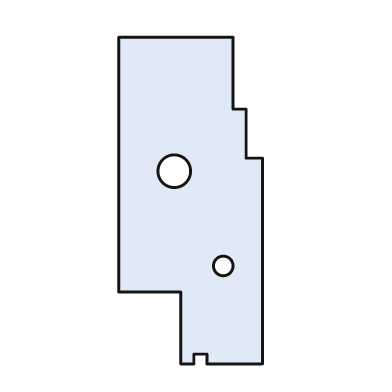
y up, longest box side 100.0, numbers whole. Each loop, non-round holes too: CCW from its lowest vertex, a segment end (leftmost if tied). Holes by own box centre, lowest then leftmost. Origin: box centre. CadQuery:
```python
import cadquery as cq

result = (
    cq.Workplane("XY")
    .moveTo(-3.0, -50.0)
    .lineTo(1.0, -50.0)
    .lineTo(1.0, -47.0)
    .lineTo(5.0, -47.0)
    .lineTo(5.0, -50.0)
    .lineTo(22.0, -50.0)
    .lineTo(22.0, 13.0)
    .lineTo(17.0, 13.0)
    .lineTo(17.0, 28.0)
    .lineTo(13.0, 28.0)
    .lineTo(13.0, 50.0)
    .lineTo(-22.0, 50.0)
    .lineTo(-22.0, -28.0)
    .lineTo(-3.0, -28.0)
    .close()
    .moveTo(10.0, -20.0)
    .circle(3.0)
    .moveTo(-5.0, 9.0)
    .circle(5.0)
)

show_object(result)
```